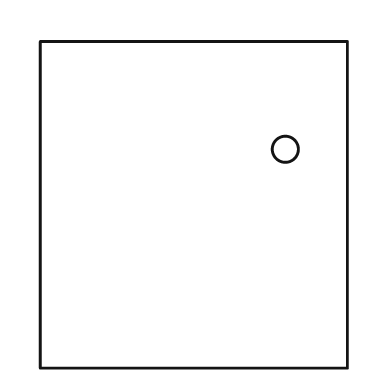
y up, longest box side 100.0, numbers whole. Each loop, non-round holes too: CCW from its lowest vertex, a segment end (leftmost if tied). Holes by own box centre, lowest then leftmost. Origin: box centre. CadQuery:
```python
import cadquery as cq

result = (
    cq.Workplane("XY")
    .moveTo(-47.0, -50.0)
    .lineTo(47.0, -50.0)
    .lineTo(47.0, 50.0)
    .lineTo(-47.0, 50.0)
    .close()
    .moveTo(28.0, 17.0)
    .circle(4.0)
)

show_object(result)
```